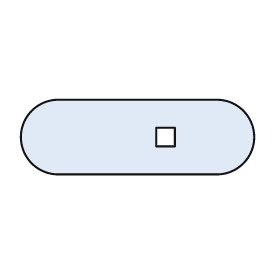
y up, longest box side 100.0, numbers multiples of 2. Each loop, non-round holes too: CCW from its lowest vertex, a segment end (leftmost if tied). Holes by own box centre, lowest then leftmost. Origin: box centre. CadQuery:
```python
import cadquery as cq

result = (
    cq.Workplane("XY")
    .moveTo(-34.0, -16.0)
    .lineTo(34.0, -16.0)
    .threePointArc((50.0, 0.0), (34.0, 16.0))
    .lineTo(-34.0, 16.0)
    .threePointArc((-50.0, 0.0), (-34.0, -16.0))
    .close()
    .moveTo(8.0, -4.0)
    .lineTo(16.0, -4.0)
    .lineTo(16.0, 4.0)
    .lineTo(8.0, 4.0)
    .close()
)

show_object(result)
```